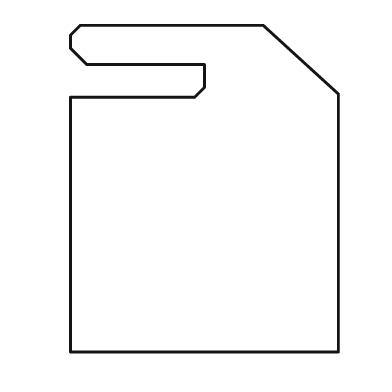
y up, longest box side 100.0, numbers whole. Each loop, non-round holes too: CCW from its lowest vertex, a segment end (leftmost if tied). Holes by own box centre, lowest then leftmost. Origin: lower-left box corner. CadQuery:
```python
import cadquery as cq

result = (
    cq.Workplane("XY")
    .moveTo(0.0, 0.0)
    .lineTo(82.0, 0.0)
    .lineTo(82.0, 79.0)
    .lineTo(59.0, 100.0)
    .lineTo(3.0, 100.0)
    .lineTo(0.0, 97.0)
    .lineTo(0.0, 93.0)
    .lineTo(5.0, 88.0)
    .lineTo(41.0, 88.0)
    .lineTo(41.0, 81.0)
    .lineTo(38.0, 78.0)
    .lineTo(0.0, 78.0)
    .close()
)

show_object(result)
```